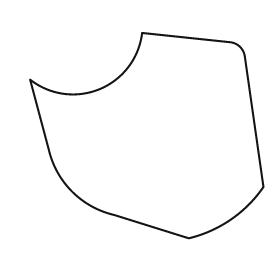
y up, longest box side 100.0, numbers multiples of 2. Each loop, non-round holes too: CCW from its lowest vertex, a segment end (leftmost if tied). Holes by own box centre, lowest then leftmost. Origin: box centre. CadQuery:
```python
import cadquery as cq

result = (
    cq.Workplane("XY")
    .moveTo(18.0, -44.0)
    .threePointArc((36.0, -36.0), (50.0, -22.0))
    .lineTo(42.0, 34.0)
    .threePointArc((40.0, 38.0), (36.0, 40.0))
    .lineTo(-2.0, 44.0)
    .threePointArc((-20.0, 20.0), (-50.0, 24.0))
    .lineTo(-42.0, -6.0)
    .threePointArc((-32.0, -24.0), (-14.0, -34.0))
    .close()
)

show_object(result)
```